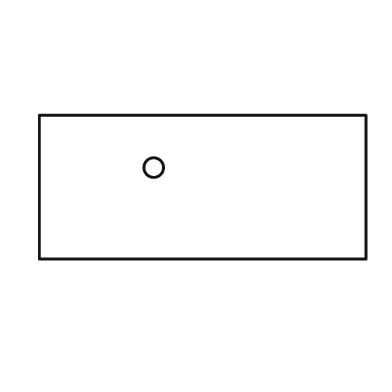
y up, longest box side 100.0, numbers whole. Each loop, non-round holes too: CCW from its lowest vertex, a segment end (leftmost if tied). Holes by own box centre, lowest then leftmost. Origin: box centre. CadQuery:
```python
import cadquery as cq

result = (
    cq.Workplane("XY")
    .moveTo(-50.0, -22.0)
    .lineTo(50.0, -22.0)
    .lineTo(50.0, 22.0)
    .lineTo(-50.0, 22.0)
    .close()
    .moveTo(-15.0, 6.0)
    .circle(3.0)
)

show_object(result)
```